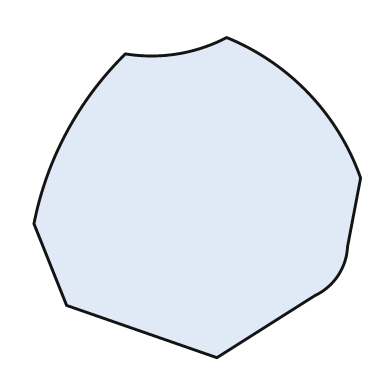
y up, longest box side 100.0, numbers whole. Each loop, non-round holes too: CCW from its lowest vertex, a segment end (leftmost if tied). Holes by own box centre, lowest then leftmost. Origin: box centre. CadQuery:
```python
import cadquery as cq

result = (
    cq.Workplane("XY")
    .moveTo(6.0, -49.0)
    .lineTo(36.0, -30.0)
    .threePointArc((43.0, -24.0), (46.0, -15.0))
    .lineTo(50.0, 6.0)
    .threePointArc((34.0, 32.0), (9.0, 49.0))
    .threePointArc((-6.0, 44.0), (-22.0, 44.0))
    .threePointArc((-40.0, 20.0), (-50.0, -8.0))
    .lineTo(-40.0, -33.0)
    .close()
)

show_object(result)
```